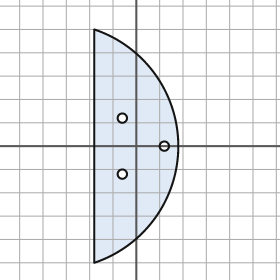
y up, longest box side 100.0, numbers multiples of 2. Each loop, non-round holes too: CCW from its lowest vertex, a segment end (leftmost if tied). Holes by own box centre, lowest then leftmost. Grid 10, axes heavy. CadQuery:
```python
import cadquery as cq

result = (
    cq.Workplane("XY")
    .moveTo(-18.0, -50.0)
    .threePointArc((18.0, 0.0), (-18.0, 50.0))
    .close()
    .moveTo(-6.0, -12.0)
    .circle(2.0)
    .moveTo(12.0, 0.0)
    .circle(2.0)
    .moveTo(-6.0, 12.0)
    .circle(2.0)
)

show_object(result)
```